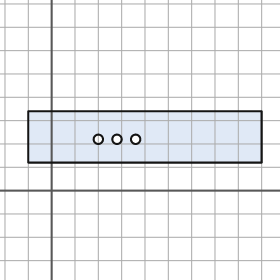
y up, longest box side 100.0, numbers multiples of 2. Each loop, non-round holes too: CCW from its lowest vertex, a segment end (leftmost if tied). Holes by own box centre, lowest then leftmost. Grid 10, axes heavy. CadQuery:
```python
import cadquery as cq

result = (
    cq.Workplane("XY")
    .moveTo(-10.0, 12.0)
    .lineTo(90.0, 12.0)
    .lineTo(90.0, 34.0)
    .lineTo(-10.0, 34.0)
    .close()
    .moveTo(20.0, 22.0)
    .circle(2.0)
    .moveTo(28.0, 22.0)
    .circle(2.0)
    .moveTo(36.0, 22.0)
    .circle(2.0)
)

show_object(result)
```